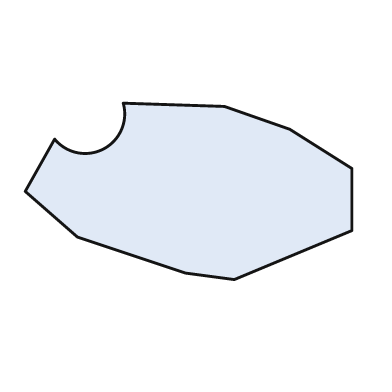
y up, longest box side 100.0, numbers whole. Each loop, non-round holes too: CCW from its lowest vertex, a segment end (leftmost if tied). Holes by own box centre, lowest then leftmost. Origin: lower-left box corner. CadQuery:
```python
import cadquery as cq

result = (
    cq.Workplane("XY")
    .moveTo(64.0, 0.0)
    .lineTo(100.0, 15.0)
    .lineTo(100.0, 34.0)
    .lineTo(81.0, 46.0)
    .lineTo(61.0, 53.0)
    .lineTo(30.0, 54.0)
    .threePointArc((24.0, 40.0), (9.0, 43.0))
    .lineTo(0.0, 27.0)
    .lineTo(16.0, 13.0)
    .lineTo(49.0, 2.0)
    .close()
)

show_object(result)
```